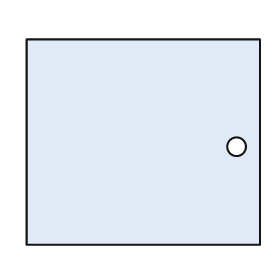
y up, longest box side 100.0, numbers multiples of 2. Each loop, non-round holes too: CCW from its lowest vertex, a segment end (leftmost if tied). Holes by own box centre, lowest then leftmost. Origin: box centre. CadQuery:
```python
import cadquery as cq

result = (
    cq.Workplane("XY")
    .moveTo(-50.0, -44.0)
    .lineTo(50.0, -44.0)
    .lineTo(50.0, 44.0)
    .lineTo(-50.0, 44.0)
    .close()
    .moveTo(40.0, -2.0)
    .circle(4.0)
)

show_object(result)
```